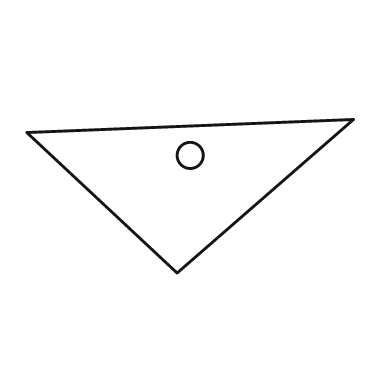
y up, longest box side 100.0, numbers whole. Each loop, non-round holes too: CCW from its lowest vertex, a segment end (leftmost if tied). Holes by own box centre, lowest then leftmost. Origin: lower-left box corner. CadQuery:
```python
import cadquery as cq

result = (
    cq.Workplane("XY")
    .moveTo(46.0, 0.0)
    .lineTo(100.0, 47.0)
    .lineTo(0.0, 43.0)
    .close()
    .moveTo(50.0, 36.0)
    .circle(4.0)
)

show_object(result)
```